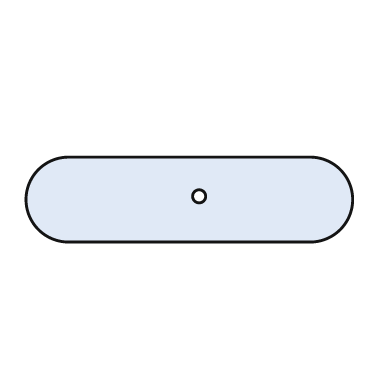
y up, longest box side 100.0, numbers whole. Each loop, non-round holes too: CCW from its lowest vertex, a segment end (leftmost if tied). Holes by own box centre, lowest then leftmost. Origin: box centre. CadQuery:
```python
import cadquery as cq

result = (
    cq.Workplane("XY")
    .moveTo(-37.0, -13.0)
    .lineTo(37.0, -13.0)
    .threePointArc((50.0, 0.0), (37.0, 13.0))
    .lineTo(-37.0, 13.0)
    .threePointArc((-50.0, 0.0), (-37.0, -13.0))
    .close()
    .moveTo(3.0, 1.0)
    .circle(2.0)
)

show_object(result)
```